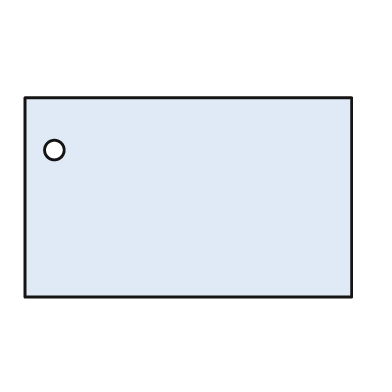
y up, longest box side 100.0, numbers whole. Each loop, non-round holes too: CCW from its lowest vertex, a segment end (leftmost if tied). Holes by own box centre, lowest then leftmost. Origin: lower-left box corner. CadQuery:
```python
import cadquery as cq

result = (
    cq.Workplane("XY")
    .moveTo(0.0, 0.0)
    .lineTo(100.0, 0.0)
    .lineTo(100.0, 61.0)
    .lineTo(0.0, 61.0)
    .close()
    .moveTo(9.0, 45.0)
    .circle(3.0)
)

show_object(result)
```